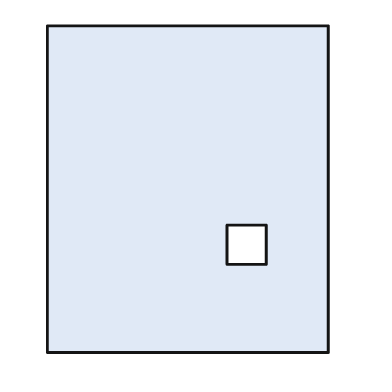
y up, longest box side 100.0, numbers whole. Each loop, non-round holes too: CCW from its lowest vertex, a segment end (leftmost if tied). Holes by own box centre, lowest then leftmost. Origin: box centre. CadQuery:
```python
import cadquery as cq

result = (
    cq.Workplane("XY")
    .moveTo(-43.0, -50.0)
    .lineTo(43.0, -50.0)
    .lineTo(43.0, 50.0)
    .lineTo(-43.0, 50.0)
    .close()
    .moveTo(12.0, -23.0)
    .lineTo(24.0, -23.0)
    .lineTo(24.0, -11.0)
    .lineTo(12.0, -11.0)
    .close()
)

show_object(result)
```